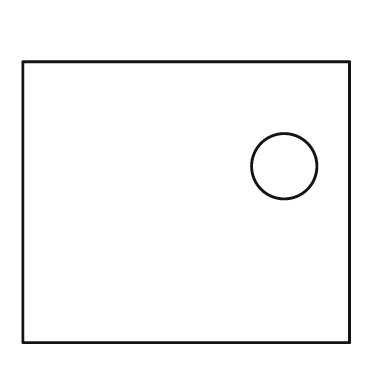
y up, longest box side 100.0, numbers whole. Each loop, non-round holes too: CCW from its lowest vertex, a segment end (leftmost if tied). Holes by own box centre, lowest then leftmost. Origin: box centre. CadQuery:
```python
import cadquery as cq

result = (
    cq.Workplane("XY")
    .moveTo(-50.0, -43.0)
    .lineTo(50.0, -43.0)
    .lineTo(50.0, 43.0)
    .lineTo(-50.0, 43.0)
    .close()
    .moveTo(30.0, 11.0)
    .circle(10.0)
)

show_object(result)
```